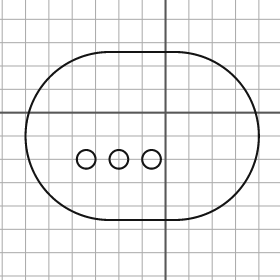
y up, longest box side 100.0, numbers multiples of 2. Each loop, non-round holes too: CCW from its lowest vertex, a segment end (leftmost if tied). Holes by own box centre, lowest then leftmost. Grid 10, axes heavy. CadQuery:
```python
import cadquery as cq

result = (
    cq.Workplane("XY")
    .moveTo(-24.0, -46.0)
    .lineTo(4.0, -46.0)
    .threePointArc((40.0, -10.0), (4.0, 26.0))
    .lineTo(-24.0, 26.0)
    .threePointArc((-60.0, -10.0), (-24.0, -46.0))
    .close()
    .moveTo(-34.0, -20.0)
    .circle(4.0)
    .moveTo(-20.0, -20.0)
    .circle(4.0)
    .moveTo(-6.0, -20.0)
    .circle(4.0)
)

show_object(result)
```